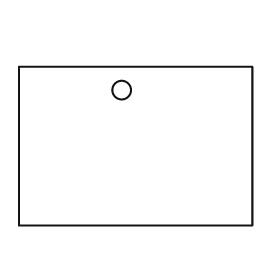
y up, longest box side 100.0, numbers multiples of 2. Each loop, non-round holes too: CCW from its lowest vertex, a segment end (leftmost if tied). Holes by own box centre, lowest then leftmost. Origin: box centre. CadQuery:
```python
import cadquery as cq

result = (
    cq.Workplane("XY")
    .moveTo(-50.0, -34.0)
    .lineTo(50.0, -34.0)
    .lineTo(50.0, 34.0)
    .lineTo(-50.0, 34.0)
    .close()
    .moveTo(-6.0, 24.0)
    .circle(4.0)
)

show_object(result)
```